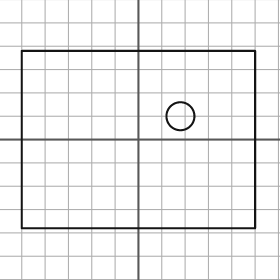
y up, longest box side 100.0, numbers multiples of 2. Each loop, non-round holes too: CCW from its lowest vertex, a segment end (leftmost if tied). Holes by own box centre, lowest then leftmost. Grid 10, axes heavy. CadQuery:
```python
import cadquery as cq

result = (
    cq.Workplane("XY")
    .moveTo(-50.0, -38.0)
    .lineTo(50.0, -38.0)
    .lineTo(50.0, 38.0)
    .lineTo(-50.0, 38.0)
    .close()
    .moveTo(18.0, 10.0)
    .circle(6.0)
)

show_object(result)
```